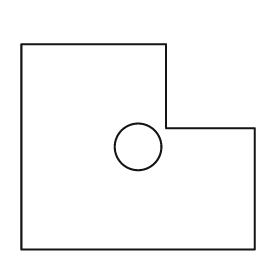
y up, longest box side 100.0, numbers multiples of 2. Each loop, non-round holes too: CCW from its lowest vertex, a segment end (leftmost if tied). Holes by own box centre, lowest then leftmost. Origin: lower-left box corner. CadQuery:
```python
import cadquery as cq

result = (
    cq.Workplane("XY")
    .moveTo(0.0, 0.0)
    .lineTo(100.0, 0.0)
    .lineTo(100.0, 52.0)
    .lineTo(62.0, 52.0)
    .lineTo(62.0, 88.0)
    .lineTo(0.0, 88.0)
    .close()
    .moveTo(50.0, 44.0)
    .circle(10.0)
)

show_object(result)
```